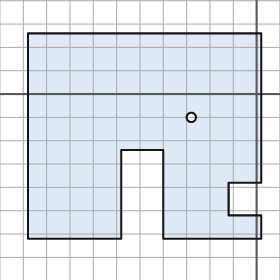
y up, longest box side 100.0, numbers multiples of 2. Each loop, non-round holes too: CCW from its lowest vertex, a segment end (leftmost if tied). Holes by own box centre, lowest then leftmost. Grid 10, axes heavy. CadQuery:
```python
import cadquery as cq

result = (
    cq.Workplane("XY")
    .moveTo(-98.0, -62.0)
    .lineTo(-58.0, -62.0)
    .lineTo(-58.0, -24.0)
    .lineTo(-40.0, -24.0)
    .lineTo(-40.0, -62.0)
    .lineTo(2.0, -62.0)
    .lineTo(2.0, -52.0)
    .lineTo(-12.0, -52.0)
    .lineTo(-12.0, -38.0)
    .lineTo(2.0, -38.0)
    .lineTo(2.0, 26.0)
    .lineTo(-98.0, 26.0)
    .close()
    .moveTo(-28.0, -10.0)
    .circle(2.0)
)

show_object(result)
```